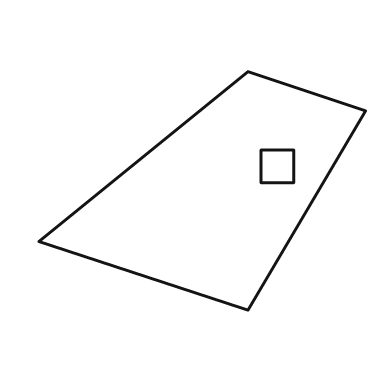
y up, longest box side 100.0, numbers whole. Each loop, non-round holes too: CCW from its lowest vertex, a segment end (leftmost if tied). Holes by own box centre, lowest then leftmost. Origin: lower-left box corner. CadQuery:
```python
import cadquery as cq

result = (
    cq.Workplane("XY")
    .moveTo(64.0, 0.0)
    .lineTo(100.0, 61.0)
    .lineTo(64.0, 73.0)
    .lineTo(0.0, 21.0)
    .close()
    .moveTo(68.0, 39.0)
    .lineTo(78.0, 39.0)
    .lineTo(78.0, 49.0)
    .lineTo(68.0, 49.0)
    .close()
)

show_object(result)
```